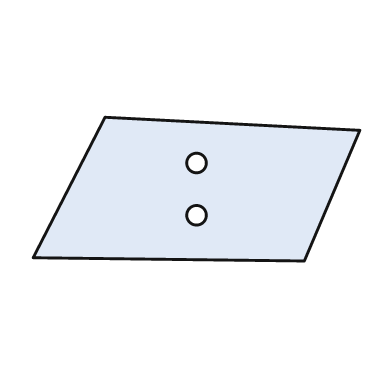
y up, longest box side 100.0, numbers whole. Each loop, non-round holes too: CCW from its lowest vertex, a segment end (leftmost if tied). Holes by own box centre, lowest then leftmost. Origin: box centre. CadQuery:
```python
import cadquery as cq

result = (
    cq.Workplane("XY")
    .moveTo(33.0, -22.0)
    .lineTo(50.0, 18.0)
    .lineTo(-28.0, 22.0)
    .lineTo(-50.0, -21.0)
    .close()
    .moveTo(0.0, -8.0)
    .circle(3.0)
    .moveTo(0.0, 8.0)
    .circle(3.0)
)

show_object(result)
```